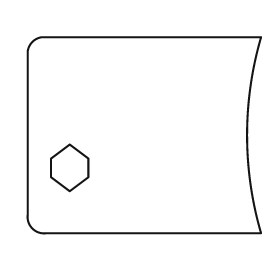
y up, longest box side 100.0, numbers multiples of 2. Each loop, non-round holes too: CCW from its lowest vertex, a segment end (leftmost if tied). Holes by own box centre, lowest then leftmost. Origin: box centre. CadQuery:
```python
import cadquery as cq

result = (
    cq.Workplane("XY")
    .moveTo(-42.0, -42.0)
    .lineTo(50.0, -42.0)
    .threePointArc((44.0, 0.0), (50.0, 42.0))
    .lineTo(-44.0, 42.0)
    .threePointArc((-48.0, 40.0), (-50.0, 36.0))
    .lineTo(-50.0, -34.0)
    .threePointArc((-48.0, -40.0), (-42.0, -42.0))
    .close()
    .moveTo(-32.0, -24.0)
    .lineTo(-24.0, -18.0)
    .lineTo(-24.0, -10.0)
    .lineTo(-32.0, -4.0)
    .lineTo(-40.0, -10.0)
    .lineTo(-40.0, -18.0)
    .close()
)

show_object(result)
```